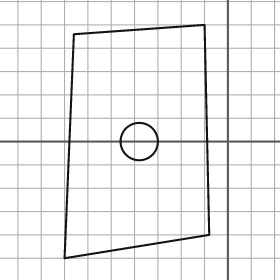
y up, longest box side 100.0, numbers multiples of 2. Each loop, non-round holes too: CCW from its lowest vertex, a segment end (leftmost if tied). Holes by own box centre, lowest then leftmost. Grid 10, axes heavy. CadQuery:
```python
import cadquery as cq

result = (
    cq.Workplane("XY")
    .moveTo(-70.0, -50.0)
    .lineTo(-8.0, -40.0)
    .lineTo(-10.0, 50.0)
    .lineTo(-66.0, 46.0)
    .close()
    .moveTo(-38.0, 0.0)
    .circle(8.0)
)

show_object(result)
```